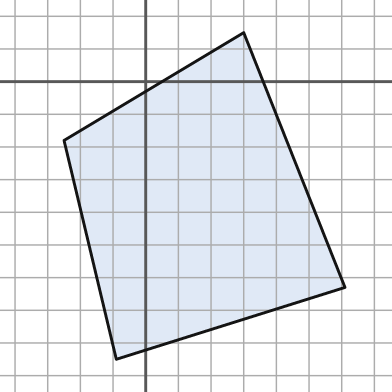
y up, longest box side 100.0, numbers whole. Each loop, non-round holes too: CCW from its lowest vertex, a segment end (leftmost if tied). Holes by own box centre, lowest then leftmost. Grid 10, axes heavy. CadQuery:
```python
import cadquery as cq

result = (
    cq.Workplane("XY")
    .moveTo(-9.0, -85.0)
    .lineTo(61.0, -63.0)
    .lineTo(30.0, 15.0)
    .lineTo(-25.0, -18.0)
    .close()
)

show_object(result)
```